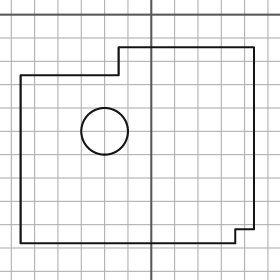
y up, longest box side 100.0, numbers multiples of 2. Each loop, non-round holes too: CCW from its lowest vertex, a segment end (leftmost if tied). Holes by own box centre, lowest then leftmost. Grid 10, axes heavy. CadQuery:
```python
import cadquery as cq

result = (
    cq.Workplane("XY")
    .moveTo(-56.0, -98.0)
    .lineTo(36.0, -98.0)
    .lineTo(36.0, -92.0)
    .lineTo(44.0, -92.0)
    .lineTo(44.0, -14.0)
    .lineTo(-14.0, -14.0)
    .lineTo(-14.0, -26.0)
    .lineTo(-56.0, -26.0)
    .close()
    .moveTo(-20.0, -50.0)
    .circle(10.0)
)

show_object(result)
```